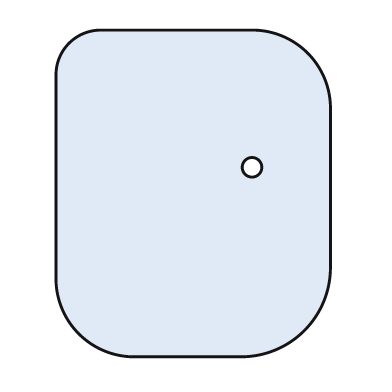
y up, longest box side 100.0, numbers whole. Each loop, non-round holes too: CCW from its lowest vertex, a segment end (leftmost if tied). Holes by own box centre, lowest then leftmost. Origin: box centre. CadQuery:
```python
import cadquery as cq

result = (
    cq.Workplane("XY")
    .moveTo(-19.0, -50.0)
    .lineTo(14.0, -50.0)
    .threePointArc((34.0, -42.0), (42.0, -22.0))
    .lineTo(42.0, 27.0)
    .threePointArc((35.0, 43.0), (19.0, 50.0))
    .lineTo(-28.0, 50.0)
    .threePointArc((-38.0, 46.0), (-42.0, 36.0))
    .lineTo(-42.0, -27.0)
    .threePointArc((-35.0, -43.0), (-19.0, -50.0))
    .close()
    .moveTo(18.0, 8.0)
    .circle(3.0)
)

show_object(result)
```